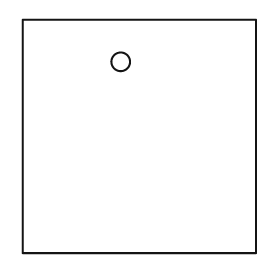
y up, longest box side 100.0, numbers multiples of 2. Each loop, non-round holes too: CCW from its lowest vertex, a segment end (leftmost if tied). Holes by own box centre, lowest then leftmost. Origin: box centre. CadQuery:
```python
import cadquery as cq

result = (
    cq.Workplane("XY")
    .moveTo(-50.0, -50.0)
    .lineTo(50.0, -50.0)
    .lineTo(50.0, 50.0)
    .lineTo(-50.0, 50.0)
    .close()
    .moveTo(-8.0, 32.0)
    .circle(4.0)
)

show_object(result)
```